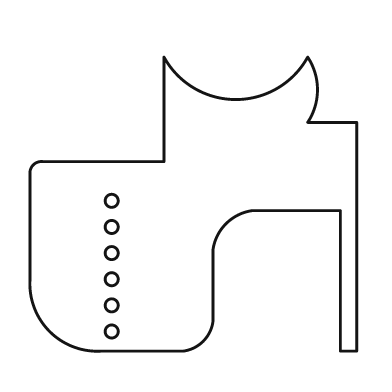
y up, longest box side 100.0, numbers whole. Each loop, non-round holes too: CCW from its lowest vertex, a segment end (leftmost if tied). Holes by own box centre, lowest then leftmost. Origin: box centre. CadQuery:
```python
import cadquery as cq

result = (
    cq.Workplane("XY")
    .moveTo(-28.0, -45.0)
    .lineTo(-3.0, -45.0)
    .threePointArc((3.0, -42.0), (6.0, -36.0))
    .lineTo(6.0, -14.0)
    .threePointArc((10.0, -6.0), (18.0, -2.0))
    .lineTo(45.0, -2.0)
    .lineTo(45.0, -45.0)
    .lineTo(50.0, -45.0)
    .lineTo(50.0, 25.0)
    .lineTo(35.0, 25.0)
    .threePointArc((38.0, 35.0), (35.0, 45.0))
    .threePointArc((13.0, 32.0), (-9.0, 45.0))
    .lineTo(-9.0, 13.0)
    .lineTo(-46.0, 13.0)
    .threePointArc((-49.0, 12.0), (-50.0, 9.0))
    .lineTo(-50.0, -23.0)
    .threePointArc((-44.0, -39.0), (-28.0, -45.0))
    .close()
    .moveTo(-25.0, -39.0)
    .circle(2.0)
    .moveTo(-25.0, -31.0)
    .circle(2.0)
    .moveTo(-25.0, -23.0)
    .circle(2.0)
    .moveTo(-25.0, -15.0)
    .circle(2.0)
    .moveTo(-25.0, -7.0)
    .circle(2.0)
    .moveTo(-25.0, 1.0)
    .circle(2.0)
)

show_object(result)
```